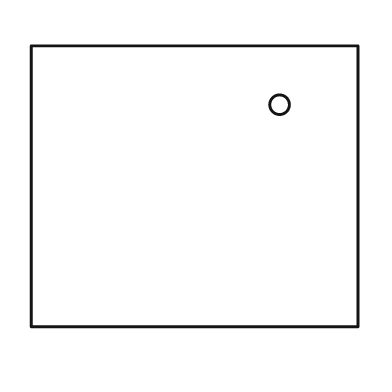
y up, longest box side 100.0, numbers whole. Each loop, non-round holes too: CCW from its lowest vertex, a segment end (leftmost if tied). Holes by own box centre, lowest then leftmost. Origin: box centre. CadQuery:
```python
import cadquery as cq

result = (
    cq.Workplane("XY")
    .moveTo(-50.0, -43.0)
    .lineTo(50.0, -43.0)
    .lineTo(50.0, 43.0)
    .lineTo(-50.0, 43.0)
    .close()
    .moveTo(26.0, 25.0)
    .circle(3.0)
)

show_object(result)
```